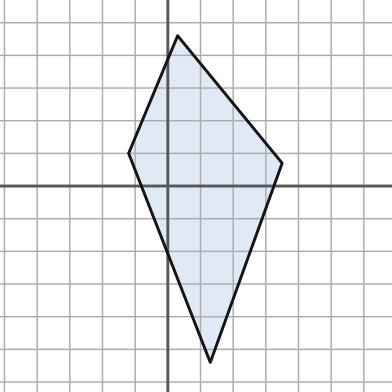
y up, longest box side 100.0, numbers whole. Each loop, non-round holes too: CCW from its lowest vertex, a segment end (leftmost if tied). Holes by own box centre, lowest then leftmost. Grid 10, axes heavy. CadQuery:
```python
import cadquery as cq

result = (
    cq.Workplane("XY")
    .moveTo(13.0, -54.0)
    .lineTo(35.0, 7.0)
    .lineTo(3.0, 46.0)
    .lineTo(-12.0, 10.0)
    .close()
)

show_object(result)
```